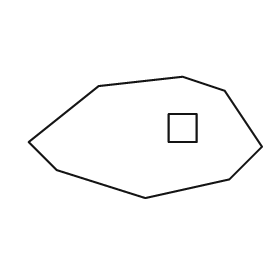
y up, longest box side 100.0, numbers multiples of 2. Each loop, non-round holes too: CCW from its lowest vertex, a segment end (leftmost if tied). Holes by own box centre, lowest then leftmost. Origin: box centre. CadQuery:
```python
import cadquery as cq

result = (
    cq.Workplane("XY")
    .moveTo(0.0, -26.0)
    .lineTo(36.0, -18.0)
    .lineTo(50.0, -4.0)
    .lineTo(34.0, 20.0)
    .lineTo(16.0, 26.0)
    .lineTo(-20.0, 22.0)
    .lineTo(-50.0, -2.0)
    .lineTo(-38.0, -14.0)
    .close()
    .moveTo(10.0, -2.0)
    .lineTo(22.0, -2.0)
    .lineTo(22.0, 10.0)
    .lineTo(10.0, 10.0)
    .close()
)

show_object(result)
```